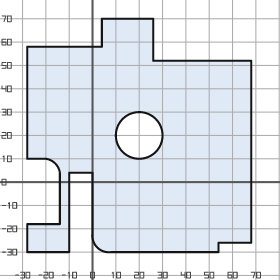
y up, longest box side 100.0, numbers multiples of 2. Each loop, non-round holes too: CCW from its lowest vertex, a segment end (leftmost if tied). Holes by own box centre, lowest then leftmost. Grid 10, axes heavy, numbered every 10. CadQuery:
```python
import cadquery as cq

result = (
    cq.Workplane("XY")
    .moveTo(-28.0, -30.0)
    .lineTo(-10.0, -30.0)
    .lineTo(-10.0, 4.0)
    .lineTo(0.0, 4.0)
    .lineTo(0.0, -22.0)
    .threePointArc((2.0, -28.0), (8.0, -30.0))
    .lineTo(54.0, -30.0)
    .lineTo(54.0, -26.0)
    .lineTo(68.0, -26.0)
    .lineTo(68.0, 52.0)
    .lineTo(26.0, 52.0)
    .lineTo(26.0, 70.0)
    .lineTo(4.0, 70.0)
    .lineTo(4.0, 58.0)
    .lineTo(-28.0, 58.0)
    .lineTo(-28.0, 10.0)
    .lineTo(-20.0, 10.0)
    .threePointArc((-16.0, 8.0), (-14.0, 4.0))
    .lineTo(-14.0, -18.0)
    .lineTo(-28.0, -18.0)
    .close()
    .moveTo(20.0, 20.0)
    .circle(10.0)
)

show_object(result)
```